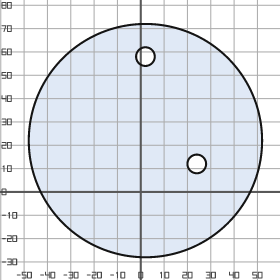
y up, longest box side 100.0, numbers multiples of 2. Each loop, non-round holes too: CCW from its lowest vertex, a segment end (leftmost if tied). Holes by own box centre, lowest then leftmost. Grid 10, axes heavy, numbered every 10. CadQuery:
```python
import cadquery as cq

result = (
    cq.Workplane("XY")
    .moveTo(2.0, 22.0)
    .circle(50.0)
    .moveTo(24.0, 12.0)
    .circle(4.0)
    .moveTo(2.0, 58.0)
    .circle(4.0)
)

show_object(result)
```